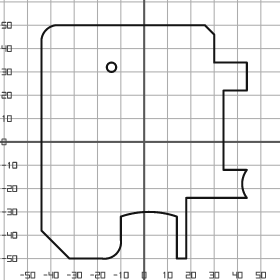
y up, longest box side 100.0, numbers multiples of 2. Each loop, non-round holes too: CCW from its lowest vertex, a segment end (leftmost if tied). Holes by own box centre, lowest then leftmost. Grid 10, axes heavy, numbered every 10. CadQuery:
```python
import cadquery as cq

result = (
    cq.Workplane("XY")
    .moveTo(-32.0, -50.0)
    .lineTo(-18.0, -50.0)
    .threePointArc((-12.0, -48.0), (-10.0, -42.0))
    .lineTo(-10.0, -32.0)
    .threePointArc((2.0, -30.0), (14.0, -32.0))
    .lineTo(14.0, -50.0)
    .lineTo(18.0, -50.0)
    .lineTo(18.0, -24.0)
    .lineTo(44.0, -24.0)
    .threePointArc((42.0, -18.0), (44.0, -12.0))
    .lineTo(34.0, -12.0)
    .lineTo(34.0, 22.0)
    .lineTo(44.0, 22.0)
    .lineTo(44.0, 34.0)
    .lineTo(30.0, 34.0)
    .lineTo(30.0, 46.0)
    .lineTo(26.0, 50.0)
    .lineTo(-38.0, 50.0)
    .threePointArc((-42.0, 48.0), (-44.0, 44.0))
    .lineTo(-44.0, -38.0)
    .close()
    .moveTo(-14.0, 32.0)
    .circle(2.0)
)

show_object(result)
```